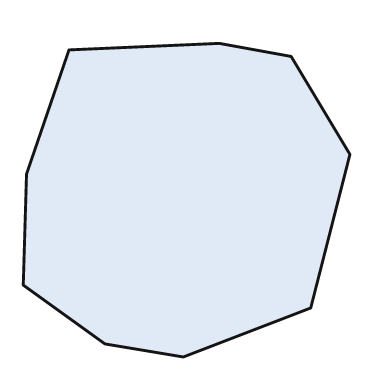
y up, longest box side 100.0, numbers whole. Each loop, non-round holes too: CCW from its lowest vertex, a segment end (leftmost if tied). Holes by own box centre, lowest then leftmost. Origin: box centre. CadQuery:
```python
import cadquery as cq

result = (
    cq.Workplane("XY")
    .moveTo(-1.0, -48.0)
    .lineTo(38.0, -33.0)
    .lineTo(50.0, 14.0)
    .lineTo(32.0, 44.0)
    .lineTo(10.0, 48.0)
    .lineTo(-36.0, 46.0)
    .lineTo(-49.0, 8.0)
    .lineTo(-50.0, -26.0)
    .lineTo(-25.0, -44.0)
    .close()
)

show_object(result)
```